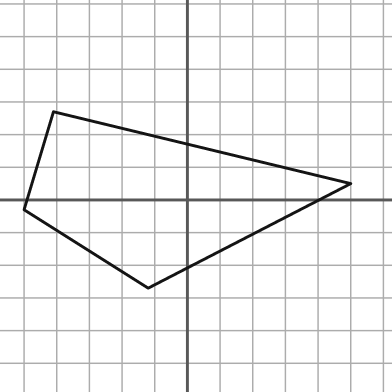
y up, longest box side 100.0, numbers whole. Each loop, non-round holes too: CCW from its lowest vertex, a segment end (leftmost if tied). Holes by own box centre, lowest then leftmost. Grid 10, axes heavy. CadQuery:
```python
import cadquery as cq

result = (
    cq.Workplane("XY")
    .moveTo(-12.0, -27.0)
    .lineTo(50.0, 5.0)
    .lineTo(-41.0, 27.0)
    .lineTo(-50.0, -3.0)
    .close()
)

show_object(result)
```